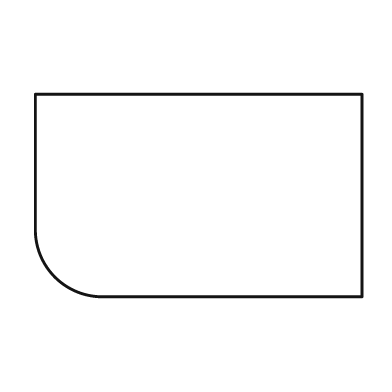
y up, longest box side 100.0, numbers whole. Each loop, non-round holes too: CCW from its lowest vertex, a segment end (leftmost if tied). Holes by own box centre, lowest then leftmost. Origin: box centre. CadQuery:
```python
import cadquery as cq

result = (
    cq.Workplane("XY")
    .moveTo(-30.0, -31.0)
    .lineTo(50.0, -31.0)
    .lineTo(50.0, 31.0)
    .lineTo(-50.0, 31.0)
    .lineTo(-50.0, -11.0)
    .threePointArc((-44.0, -25.0), (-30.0, -31.0))
    .close()
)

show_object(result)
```